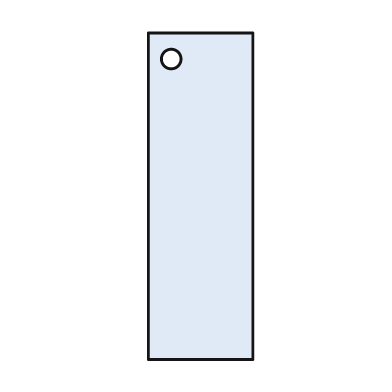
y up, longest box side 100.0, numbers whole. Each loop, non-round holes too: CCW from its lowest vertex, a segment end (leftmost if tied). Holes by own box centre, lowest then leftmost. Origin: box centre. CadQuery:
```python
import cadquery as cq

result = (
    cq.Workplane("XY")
    .moveTo(-16.0, -50.0)
    .lineTo(16.0, -50.0)
    .lineTo(16.0, 50.0)
    .lineTo(-16.0, 50.0)
    .close()
    .moveTo(-9.0, 42.0)
    .circle(3.0)
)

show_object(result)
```